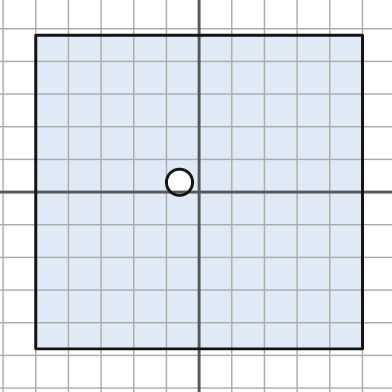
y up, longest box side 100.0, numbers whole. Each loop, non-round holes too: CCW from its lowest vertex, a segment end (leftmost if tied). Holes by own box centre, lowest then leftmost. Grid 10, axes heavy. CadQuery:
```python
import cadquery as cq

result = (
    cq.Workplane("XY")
    .moveTo(-50.0, -48.0)
    .lineTo(50.0, -48.0)
    .lineTo(50.0, 48.0)
    .lineTo(-50.0, 48.0)
    .close()
    .moveTo(-6.0, 3.0)
    .circle(4.0)
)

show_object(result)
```